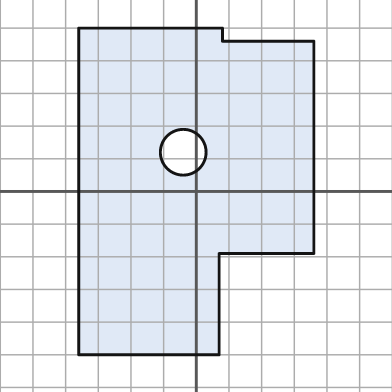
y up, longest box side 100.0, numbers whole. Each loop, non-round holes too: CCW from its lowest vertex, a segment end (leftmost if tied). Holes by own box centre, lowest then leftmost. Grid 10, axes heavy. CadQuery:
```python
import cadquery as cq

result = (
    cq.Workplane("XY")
    .moveTo(-36.0, -50.0)
    .lineTo(7.0, -50.0)
    .lineTo(7.0, -19.0)
    .lineTo(36.0, -19.0)
    .lineTo(36.0, 46.0)
    .lineTo(8.0, 46.0)
    .lineTo(8.0, 50.0)
    .lineTo(-36.0, 50.0)
    .close()
    .moveTo(-4.0, 12.0)
    .circle(7.0)
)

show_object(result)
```